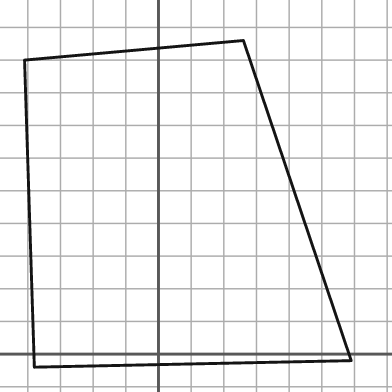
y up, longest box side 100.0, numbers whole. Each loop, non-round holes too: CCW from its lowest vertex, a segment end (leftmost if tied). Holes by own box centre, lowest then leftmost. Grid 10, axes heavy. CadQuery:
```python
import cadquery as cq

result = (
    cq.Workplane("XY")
    .moveTo(-38.0, -4.0)
    .lineTo(59.0, -2.0)
    .lineTo(26.0, 96.0)
    .lineTo(-41.0, 90.0)
    .close()
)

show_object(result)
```